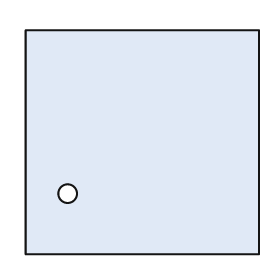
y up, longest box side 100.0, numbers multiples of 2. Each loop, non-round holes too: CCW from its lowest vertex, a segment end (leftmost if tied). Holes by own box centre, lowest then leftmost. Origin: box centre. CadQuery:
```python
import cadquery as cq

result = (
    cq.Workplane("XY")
    .moveTo(-50.0, -48.0)
    .lineTo(50.0, -48.0)
    .lineTo(50.0, 48.0)
    .lineTo(-50.0, 48.0)
    .close()
    .moveTo(-32.0, -22.0)
    .circle(4.0)
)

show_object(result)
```